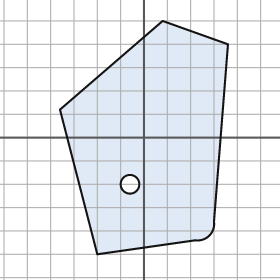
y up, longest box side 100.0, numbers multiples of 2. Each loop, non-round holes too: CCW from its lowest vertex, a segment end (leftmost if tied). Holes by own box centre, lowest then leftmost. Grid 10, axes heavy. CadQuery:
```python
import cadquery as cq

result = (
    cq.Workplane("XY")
    .moveTo(-20.0, -50.0)
    .lineTo(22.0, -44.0)
    .threePointArc((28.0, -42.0), (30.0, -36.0))
    .lineTo(36.0, 40.0)
    .lineTo(8.0, 50.0)
    .lineTo(-36.0, 12.0)
    .close()
    .moveTo(-6.0, -20.0)
    .circle(4.0)
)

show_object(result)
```